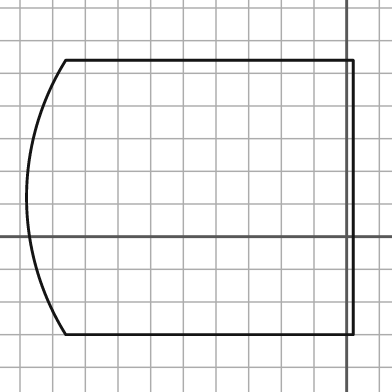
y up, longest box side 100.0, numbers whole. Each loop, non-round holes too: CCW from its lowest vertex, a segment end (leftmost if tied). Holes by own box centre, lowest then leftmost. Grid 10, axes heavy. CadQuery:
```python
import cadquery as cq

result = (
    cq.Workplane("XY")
    .moveTo(-86.0, -30.0)
    .lineTo(2.0, -30.0)
    .lineTo(2.0, 54.0)
    .lineTo(-86.0, 54.0)
    .threePointArc((-98.0, 12.0), (-86.0, -30.0))
    .close()
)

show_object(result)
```